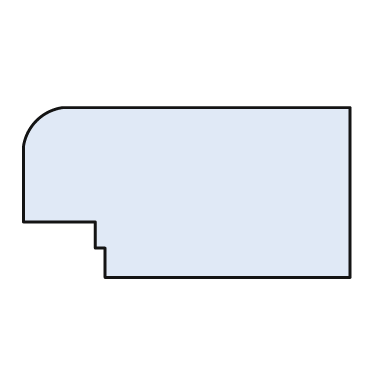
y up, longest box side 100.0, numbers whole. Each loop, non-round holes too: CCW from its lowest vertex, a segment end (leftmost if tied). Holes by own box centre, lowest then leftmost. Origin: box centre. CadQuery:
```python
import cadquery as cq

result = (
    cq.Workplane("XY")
    .moveTo(-25.0, -26.0)
    .lineTo(50.0, -26.0)
    .lineTo(50.0, 26.0)
    .lineTo(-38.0, 26.0)
    .threePointArc((-46.0, 22.0), (-50.0, 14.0))
    .lineTo(-50.0, -9.0)
    .lineTo(-28.0, -9.0)
    .lineTo(-28.0, -17.0)
    .lineTo(-25.0, -17.0)
    .close()
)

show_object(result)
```